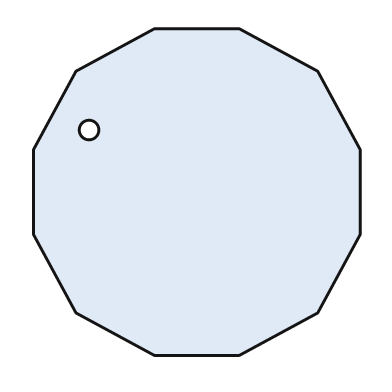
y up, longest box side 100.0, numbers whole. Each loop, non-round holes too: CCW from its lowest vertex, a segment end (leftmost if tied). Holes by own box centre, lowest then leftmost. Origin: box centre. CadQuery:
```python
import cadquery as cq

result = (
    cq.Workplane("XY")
    .moveTo(-13.0, -50.0)
    .lineTo(13.0, -50.0)
    .lineTo(37.0, -37.0)
    .lineTo(50.0, -13.0)
    .lineTo(50.0, 13.0)
    .lineTo(37.0, 37.0)
    .lineTo(13.0, 50.0)
    .lineTo(-13.0, 50.0)
    .lineTo(-37.0, 37.0)
    .lineTo(-50.0, 13.0)
    .lineTo(-50.0, -13.0)
    .lineTo(-37.0, -37.0)
    .close()
    .moveTo(-33.0, 19.0)
    .circle(3.0)
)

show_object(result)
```